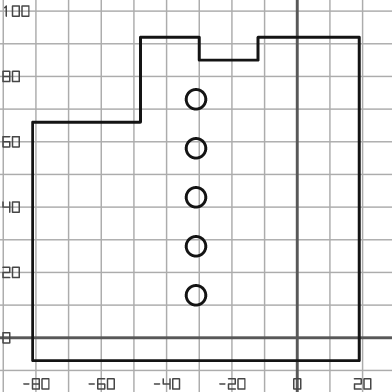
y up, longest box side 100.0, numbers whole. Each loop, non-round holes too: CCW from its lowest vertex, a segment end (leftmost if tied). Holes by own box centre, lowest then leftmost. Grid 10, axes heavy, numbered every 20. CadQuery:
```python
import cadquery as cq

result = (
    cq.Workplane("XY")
    .moveTo(-81.0, -7.0)
    .lineTo(19.0, -7.0)
    .lineTo(19.0, 92.0)
    .lineTo(-12.0, 92.0)
    .lineTo(-12.0, 85.0)
    .lineTo(-30.0, 85.0)
    .lineTo(-30.0, 92.0)
    .lineTo(-48.0, 92.0)
    .lineTo(-48.0, 66.0)
    .lineTo(-81.0, 66.0)
    .close()
    .moveTo(-31.0, 13.0)
    .circle(3.0)
    .moveTo(-31.0, 28.0)
    .circle(3.0)
    .moveTo(-31.0, 43.0)
    .circle(3.0)
    .moveTo(-31.0, 58.0)
    .circle(3.0)
    .moveTo(-31.0, 73.0)
    .circle(3.0)
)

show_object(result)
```